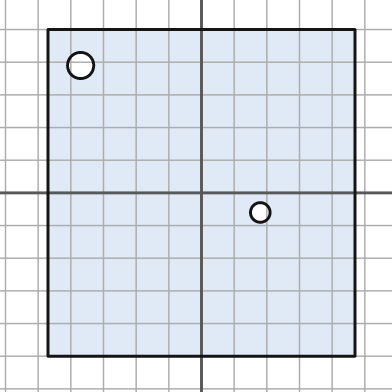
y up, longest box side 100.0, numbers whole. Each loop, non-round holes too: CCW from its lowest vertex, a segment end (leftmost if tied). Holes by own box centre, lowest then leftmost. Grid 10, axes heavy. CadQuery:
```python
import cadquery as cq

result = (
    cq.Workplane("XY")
    .moveTo(-47.0, -50.0)
    .lineTo(47.0, -50.0)
    .lineTo(47.0, 50.0)
    .lineTo(-47.0, 50.0)
    .close()
    .moveTo(18.0, -6.0)
    .circle(3.0)
    .moveTo(-37.0, 39.0)
    .circle(4.0)
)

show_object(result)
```